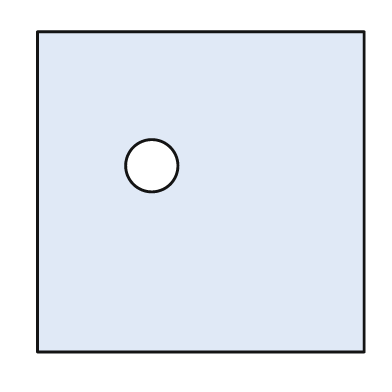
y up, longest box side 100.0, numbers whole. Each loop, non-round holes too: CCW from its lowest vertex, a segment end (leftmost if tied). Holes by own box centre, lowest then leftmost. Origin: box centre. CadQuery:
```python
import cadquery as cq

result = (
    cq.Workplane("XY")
    .moveTo(-50.0, -49.0)
    .lineTo(50.0, -49.0)
    .lineTo(50.0, 49.0)
    .lineTo(-50.0, 49.0)
    .close()
    .moveTo(-15.0, 8.0)
    .circle(8.0)
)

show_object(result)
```